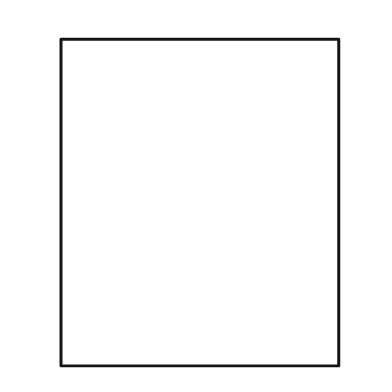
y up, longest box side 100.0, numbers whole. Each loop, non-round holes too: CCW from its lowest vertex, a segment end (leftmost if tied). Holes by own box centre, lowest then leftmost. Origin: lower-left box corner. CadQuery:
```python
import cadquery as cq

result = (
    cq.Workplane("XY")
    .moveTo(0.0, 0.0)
    .lineTo(85.0, 0.0)
    .lineTo(85.0, 100.0)
    .lineTo(0.0, 100.0)
    .close()
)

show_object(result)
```